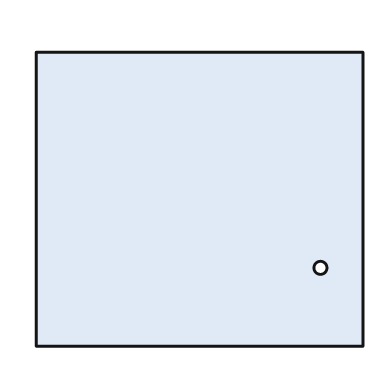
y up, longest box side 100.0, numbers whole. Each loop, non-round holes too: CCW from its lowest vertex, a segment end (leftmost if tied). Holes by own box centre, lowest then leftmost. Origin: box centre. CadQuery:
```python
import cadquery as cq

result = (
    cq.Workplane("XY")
    .moveTo(-50.0, -45.0)
    .lineTo(50.0, -45.0)
    .lineTo(50.0, 45.0)
    .lineTo(-50.0, 45.0)
    .close()
    .moveTo(37.0, -21.0)
    .circle(2.0)
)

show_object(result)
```